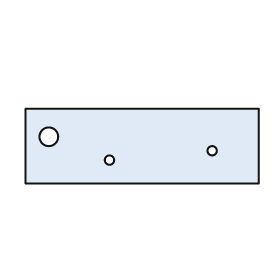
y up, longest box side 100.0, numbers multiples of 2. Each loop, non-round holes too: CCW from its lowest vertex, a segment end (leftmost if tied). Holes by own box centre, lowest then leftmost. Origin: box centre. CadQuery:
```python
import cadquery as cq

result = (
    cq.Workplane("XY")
    .moveTo(-50.0, -16.0)
    .lineTo(50.0, -16.0)
    .lineTo(50.0, 16.0)
    .lineTo(-50.0, 16.0)
    .close()
    .moveTo(-14.0, -6.0)
    .circle(2.0)
    .moveTo(30.0, -2.0)
    .circle(2.0)
    .moveTo(-40.0, 4.0)
    .circle(4.0)
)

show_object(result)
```